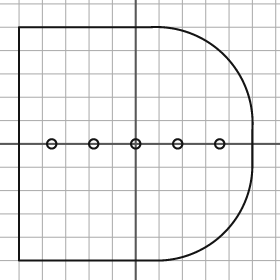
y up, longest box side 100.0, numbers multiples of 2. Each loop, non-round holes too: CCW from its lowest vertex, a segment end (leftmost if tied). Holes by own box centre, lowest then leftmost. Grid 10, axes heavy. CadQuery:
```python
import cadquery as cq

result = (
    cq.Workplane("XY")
    .moveTo(-50.0, -50.0)
    .lineTo(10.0, -50.0)
    .threePointArc((38.0, -38.0), (50.0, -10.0))
    .lineTo(50.0, 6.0)
    .threePointArc((38.0, 38.0), (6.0, 50.0))
    .lineTo(-50.0, 50.0)
    .close()
    .moveTo(-36.0, 0.0)
    .circle(2.0)
    .moveTo(-18.0, 0.0)
    .circle(2.0)
    .moveTo(0.0, 0.0)
    .circle(2.0)
    .moveTo(18.0, 0.0)
    .circle(2.0)
    .moveTo(36.0, 0.0)
    .circle(2.0)
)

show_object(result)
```